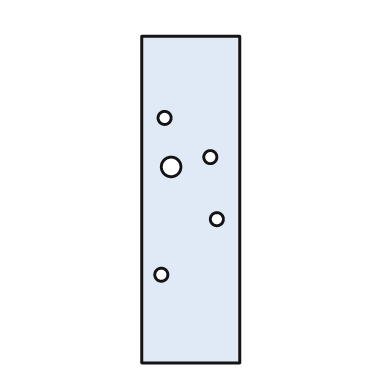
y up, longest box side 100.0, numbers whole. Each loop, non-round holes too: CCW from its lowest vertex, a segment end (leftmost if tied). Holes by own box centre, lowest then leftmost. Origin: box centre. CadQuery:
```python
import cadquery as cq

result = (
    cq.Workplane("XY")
    .moveTo(-15.0, -50.0)
    .lineTo(15.0, -50.0)
    .lineTo(15.0, 50.0)
    .lineTo(-15.0, 50.0)
    .close()
    .moveTo(-9.0, -23.0)
    .circle(2.0)
    .moveTo(8.0, -6.0)
    .circle(2.0)
    .moveTo(-6.0, 10.0)
    .circle(3.0)
    .moveTo(6.0, 13.0)
    .circle(2.0)
    .moveTo(-8.0, 25.0)
    .circle(2.0)
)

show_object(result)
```